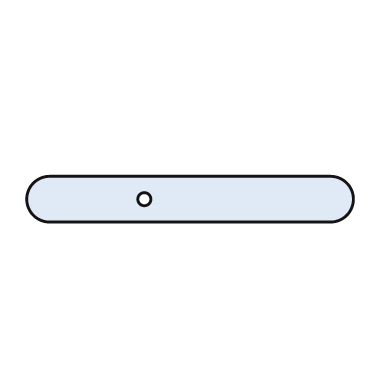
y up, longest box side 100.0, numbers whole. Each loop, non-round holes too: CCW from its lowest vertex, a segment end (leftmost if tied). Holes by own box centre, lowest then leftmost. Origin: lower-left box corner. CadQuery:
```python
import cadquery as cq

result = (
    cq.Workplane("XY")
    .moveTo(7.0, 0.0)
    .lineTo(93.0, 0.0)
    .threePointArc((100.0, 7.0), (93.0, 14.0))
    .lineTo(7.0, 14.0)
    .threePointArc((0.0, 7.0), (7.0, 0.0))
    .close()
    .moveTo(36.0, 7.0)
    .circle(2.0)
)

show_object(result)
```